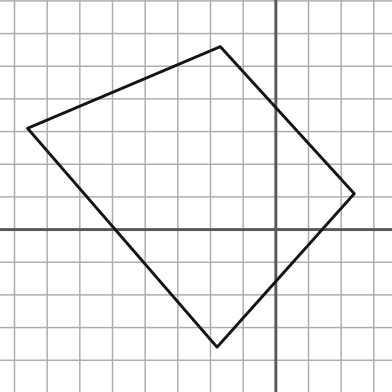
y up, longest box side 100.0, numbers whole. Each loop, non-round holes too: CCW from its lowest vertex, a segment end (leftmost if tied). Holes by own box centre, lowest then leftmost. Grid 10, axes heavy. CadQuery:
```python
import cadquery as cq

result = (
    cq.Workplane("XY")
    .moveTo(-18.0, -36.0)
    .lineTo(24.0, 11.0)
    .lineTo(-17.0, 56.0)
    .lineTo(-76.0, 31.0)
    .close()
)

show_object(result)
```